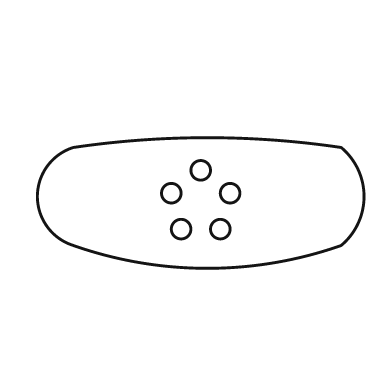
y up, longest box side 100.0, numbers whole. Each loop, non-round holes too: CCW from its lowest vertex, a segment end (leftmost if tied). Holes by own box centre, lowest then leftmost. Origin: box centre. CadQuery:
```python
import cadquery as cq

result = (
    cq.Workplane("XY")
    .moveTo(-39.0, -13.0)
    .threePointArc((2.0, -20.0), (43.0, -13.0))
    .threePointArc((50.0, 2.0), (43.0, 17.0))
    .threePointArc((2.0, 20.0), (-39.0, 17.0))
    .threePointArc((-50.0, 2.0), (-39.0, -13.0))
    .close()
    .moveTo(-6.0, -8.0)
    .circle(3.0)
    .moveTo(6.0, -8.0)
    .circle(3.0)
    .moveTo(-9.0, 3.0)
    .circle(3.0)
    .moveTo(9.0, 3.0)
    .circle(3.0)
    .moveTo(0.0, 10.0)
    .circle(3.0)
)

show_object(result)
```